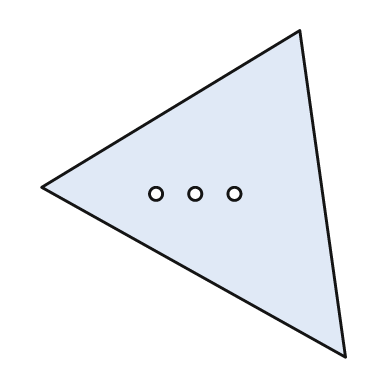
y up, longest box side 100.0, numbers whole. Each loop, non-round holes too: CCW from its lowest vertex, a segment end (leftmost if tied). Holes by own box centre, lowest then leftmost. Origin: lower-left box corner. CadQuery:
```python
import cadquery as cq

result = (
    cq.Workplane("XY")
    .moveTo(93.0, 0.0)
    .lineTo(79.0, 100.0)
    .lineTo(0.0, 52.0)
    .close()
    .moveTo(35.0, 50.0)
    .circle(2.0)
    .moveTo(47.0, 50.0)
    .circle(2.0)
    .moveTo(59.0, 50.0)
    .circle(2.0)
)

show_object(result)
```